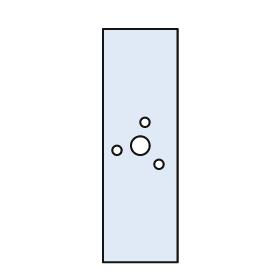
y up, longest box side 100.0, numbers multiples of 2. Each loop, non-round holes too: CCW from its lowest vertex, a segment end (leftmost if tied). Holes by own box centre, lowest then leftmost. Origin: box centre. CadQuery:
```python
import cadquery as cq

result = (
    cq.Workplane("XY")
    .moveTo(-16.0, -50.0)
    .lineTo(16.0, -50.0)
    .lineTo(16.0, 50.0)
    .lineTo(-16.0, 50.0)
    .close()
    .moveTo(8.0, -8.0)
    .circle(2.0)
    .moveTo(-10.0, -2.0)
    .circle(2.0)
    .moveTo(0.0, 0.0)
    .circle(4.0)
    .moveTo(2.0, 10.0)
    .circle(2.0)
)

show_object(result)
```